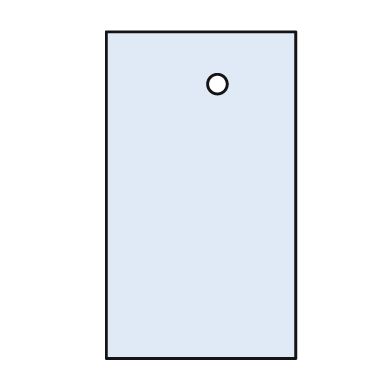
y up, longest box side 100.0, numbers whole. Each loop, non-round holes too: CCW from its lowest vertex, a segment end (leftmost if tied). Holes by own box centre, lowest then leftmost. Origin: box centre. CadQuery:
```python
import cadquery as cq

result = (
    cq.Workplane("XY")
    .moveTo(-29.0, -50.0)
    .lineTo(29.0, -50.0)
    .lineTo(29.0, 50.0)
    .lineTo(-29.0, 50.0)
    .close()
    .moveTo(5.0, 34.0)
    .circle(3.0)
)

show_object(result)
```